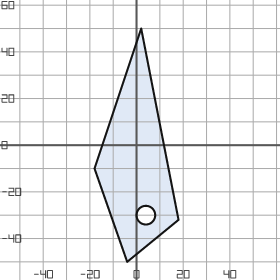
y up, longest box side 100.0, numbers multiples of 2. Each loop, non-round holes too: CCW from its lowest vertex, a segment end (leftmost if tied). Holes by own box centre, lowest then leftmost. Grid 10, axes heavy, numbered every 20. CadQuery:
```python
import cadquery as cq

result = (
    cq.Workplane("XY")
    .moveTo(-4.0, -50.0)
    .lineTo(18.0, -32.0)
    .lineTo(2.0, 50.0)
    .lineTo(-18.0, -10.0)
    .close()
    .moveTo(4.0, -30.0)
    .circle(4.0)
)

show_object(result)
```